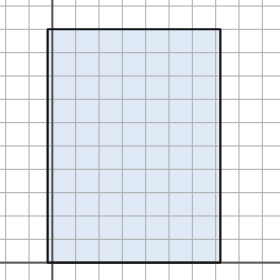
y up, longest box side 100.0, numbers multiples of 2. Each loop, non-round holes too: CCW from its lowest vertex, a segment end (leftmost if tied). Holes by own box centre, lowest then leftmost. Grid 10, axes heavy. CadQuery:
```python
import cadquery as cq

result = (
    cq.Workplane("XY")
    .moveTo(-2.0, 0.0)
    .lineTo(72.0, 0.0)
    .lineTo(72.0, 100.0)
    .lineTo(-2.0, 100.0)
    .close()
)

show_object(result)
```